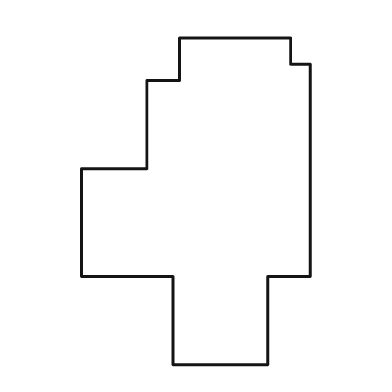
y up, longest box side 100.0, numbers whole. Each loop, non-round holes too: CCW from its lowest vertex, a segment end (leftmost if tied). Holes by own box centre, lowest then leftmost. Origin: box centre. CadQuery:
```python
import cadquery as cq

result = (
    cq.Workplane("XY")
    .moveTo(-7.0, -50.0)
    .lineTo(22.0, -50.0)
    .lineTo(22.0, -23.0)
    .lineTo(35.0, -23.0)
    .lineTo(35.0, 42.0)
    .lineTo(29.0, 42.0)
    .lineTo(29.0, 50.0)
    .lineTo(-5.0, 50.0)
    .lineTo(-5.0, 37.0)
    .lineTo(-15.0, 37.0)
    .lineTo(-15.0, 10.0)
    .lineTo(-35.0, 10.0)
    .lineTo(-35.0, -23.0)
    .lineTo(-7.0, -23.0)
    .close()
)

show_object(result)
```